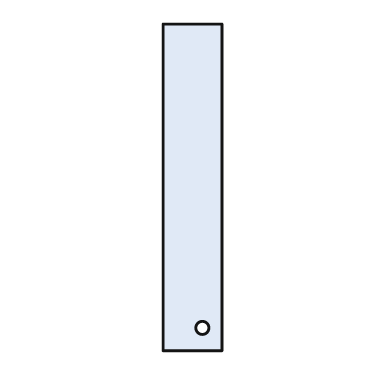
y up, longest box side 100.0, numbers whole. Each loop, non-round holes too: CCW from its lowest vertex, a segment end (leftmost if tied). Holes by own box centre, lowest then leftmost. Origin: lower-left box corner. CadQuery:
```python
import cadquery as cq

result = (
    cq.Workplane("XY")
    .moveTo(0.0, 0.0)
    .lineTo(18.0, 0.0)
    .lineTo(18.0, 100.0)
    .lineTo(0.0, 100.0)
    .close()
    .moveTo(12.0, 7.0)
    .circle(2.0)
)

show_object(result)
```